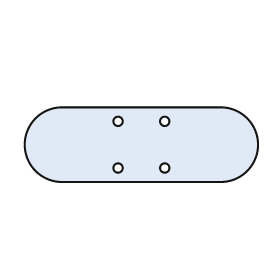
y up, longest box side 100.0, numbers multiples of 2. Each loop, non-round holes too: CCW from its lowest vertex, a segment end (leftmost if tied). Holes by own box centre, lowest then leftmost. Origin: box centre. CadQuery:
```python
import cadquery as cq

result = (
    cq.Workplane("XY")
    .moveTo(-34.0, -16.0)
    .lineTo(34.0, -16.0)
    .threePointArc((50.0, 0.0), (34.0, 16.0))
    .lineTo(-34.0, 16.0)
    .threePointArc((-50.0, 0.0), (-34.0, -16.0))
    .close()
    .moveTo(-10.0, -10.0)
    .circle(2.0)
    .moveTo(10.0, -10.0)
    .circle(2.0)
    .moveTo(-10.0, 10.0)
    .circle(2.0)
    .moveTo(10.0, 10.0)
    .circle(2.0)
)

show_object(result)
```